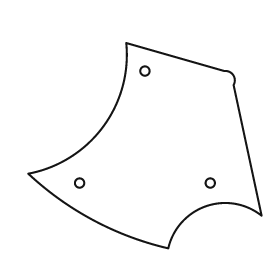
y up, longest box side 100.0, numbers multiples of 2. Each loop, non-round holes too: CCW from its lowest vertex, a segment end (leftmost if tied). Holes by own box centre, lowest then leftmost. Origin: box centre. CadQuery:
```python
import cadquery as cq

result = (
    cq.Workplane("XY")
    .moveTo(10.0, -44.0)
    .threePointArc((26.0, -26.0), (50.0, -30.0))
    .lineTo(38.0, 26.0)
    .threePointArc((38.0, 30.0), (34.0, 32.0))
    .lineTo(-8.0, 44.0)
    .threePointArc((-18.0, 8.0), (-50.0, -12.0))
    .threePointArc((-22.0, -32.0), (10.0, -44.0))
    .close()
    .moveTo(-28.0, -16.0)
    .circle(2.0)
    .moveTo(28.0, -16.0)
    .circle(2.0)
    .moveTo(0.0, 32.0)
    .circle(2.0)
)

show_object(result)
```